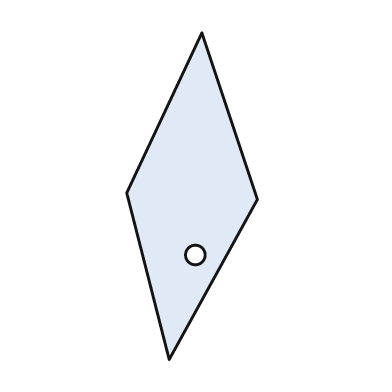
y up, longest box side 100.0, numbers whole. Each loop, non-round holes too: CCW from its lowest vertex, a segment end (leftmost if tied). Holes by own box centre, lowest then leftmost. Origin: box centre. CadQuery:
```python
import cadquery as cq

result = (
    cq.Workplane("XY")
    .moveTo(-7.0, -50.0)
    .lineTo(20.0, -1.0)
    .lineTo(3.0, 50.0)
    .lineTo(-20.0, 1.0)
    .close()
    .moveTo(1.0, -18.0)
    .circle(3.0)
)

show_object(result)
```